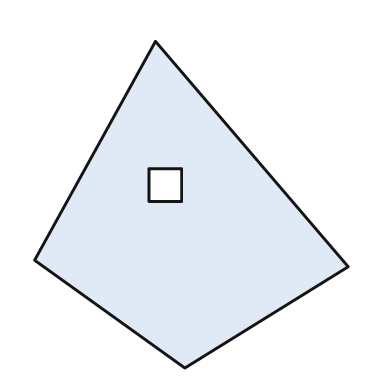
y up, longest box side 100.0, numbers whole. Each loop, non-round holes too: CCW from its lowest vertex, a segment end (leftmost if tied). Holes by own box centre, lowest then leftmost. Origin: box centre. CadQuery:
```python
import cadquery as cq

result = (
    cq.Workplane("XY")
    .moveTo(-2.0, -50.0)
    .lineTo(48.0, -19.0)
    .lineTo(-11.0, 50.0)
    .lineTo(-48.0, -17.0)
    .close()
    .moveTo(-13.0, 1.0)
    .lineTo(-3.0, 1.0)
    .lineTo(-3.0, 11.0)
    .lineTo(-13.0, 11.0)
    .close()
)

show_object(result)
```